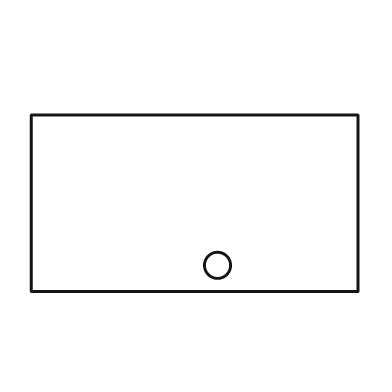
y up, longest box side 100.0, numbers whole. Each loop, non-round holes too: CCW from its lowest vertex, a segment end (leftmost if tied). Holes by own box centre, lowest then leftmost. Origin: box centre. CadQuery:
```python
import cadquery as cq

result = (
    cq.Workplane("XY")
    .moveTo(-50.0, -27.0)
    .lineTo(50.0, -27.0)
    .lineTo(50.0, 27.0)
    .lineTo(-50.0, 27.0)
    .close()
    .moveTo(7.0, -19.0)
    .circle(4.0)
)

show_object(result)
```